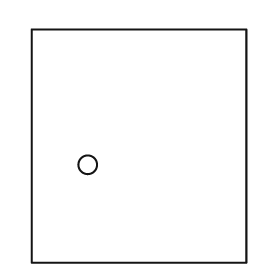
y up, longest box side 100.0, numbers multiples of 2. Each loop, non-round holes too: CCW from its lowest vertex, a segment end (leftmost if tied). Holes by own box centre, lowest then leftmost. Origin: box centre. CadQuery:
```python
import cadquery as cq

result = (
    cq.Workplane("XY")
    .moveTo(-46.0, -50.0)
    .lineTo(46.0, -50.0)
    .lineTo(46.0, 50.0)
    .lineTo(-46.0, 50.0)
    .close()
    .moveTo(-22.0, -8.0)
    .circle(4.0)
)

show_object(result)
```